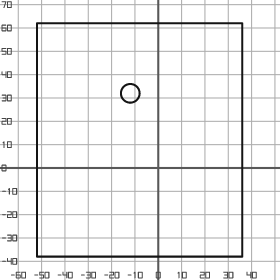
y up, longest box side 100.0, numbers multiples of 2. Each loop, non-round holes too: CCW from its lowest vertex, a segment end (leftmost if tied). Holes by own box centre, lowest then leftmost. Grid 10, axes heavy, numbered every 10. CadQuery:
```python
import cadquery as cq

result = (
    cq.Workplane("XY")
    .moveTo(-52.0, -38.0)
    .lineTo(36.0, -38.0)
    .lineTo(36.0, 62.0)
    .lineTo(-52.0, 62.0)
    .close()
    .moveTo(-12.0, 32.0)
    .circle(4.0)
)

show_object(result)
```